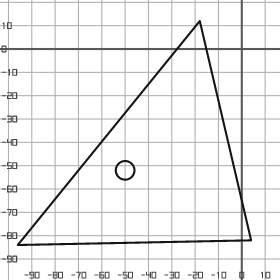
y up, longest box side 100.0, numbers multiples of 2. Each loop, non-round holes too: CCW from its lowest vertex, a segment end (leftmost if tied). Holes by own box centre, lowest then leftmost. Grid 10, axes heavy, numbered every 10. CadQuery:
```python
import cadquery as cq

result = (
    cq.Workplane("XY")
    .moveTo(-96.0, -84.0)
    .lineTo(4.0, -82.0)
    .lineTo(-18.0, 12.0)
    .close()
    .moveTo(-50.0, -52.0)
    .circle(4.0)
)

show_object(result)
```